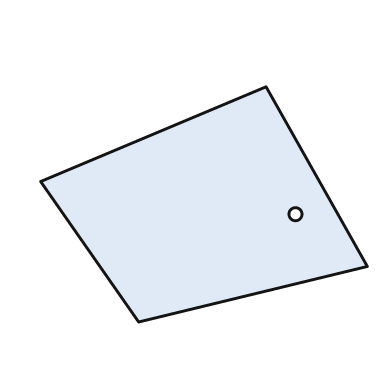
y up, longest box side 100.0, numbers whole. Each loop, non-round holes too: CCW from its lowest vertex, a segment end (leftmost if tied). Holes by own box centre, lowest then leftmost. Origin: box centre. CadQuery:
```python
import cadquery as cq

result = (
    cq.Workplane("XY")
    .moveTo(-20.0, -36.0)
    .lineTo(50.0, -19.0)
    .lineTo(19.0, 36.0)
    .lineTo(-50.0, 7.0)
    .close()
    .moveTo(28.0, -3.0)
    .circle(2.0)
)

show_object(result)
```